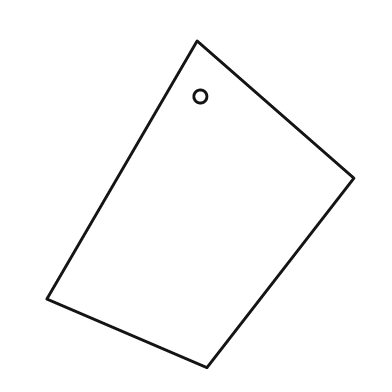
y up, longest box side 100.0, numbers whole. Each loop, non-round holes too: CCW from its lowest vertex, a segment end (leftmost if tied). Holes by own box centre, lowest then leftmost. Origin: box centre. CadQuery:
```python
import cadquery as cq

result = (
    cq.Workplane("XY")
    .moveTo(2.0, -50.0)
    .lineTo(47.0, 8.0)
    .lineTo(-1.0, 50.0)
    .lineTo(-47.0, -29.0)
    .close()
    .moveTo(0.0, 33.0)
    .circle(2.0)
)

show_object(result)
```